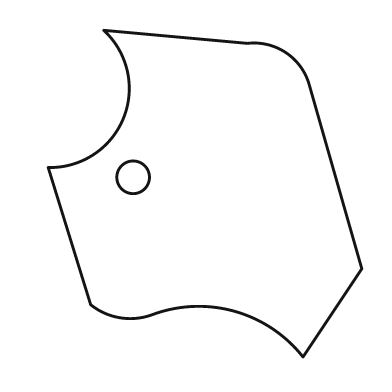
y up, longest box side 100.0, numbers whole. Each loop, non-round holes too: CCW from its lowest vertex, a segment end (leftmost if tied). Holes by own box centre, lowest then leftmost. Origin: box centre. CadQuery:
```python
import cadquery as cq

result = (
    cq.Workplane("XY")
    .moveTo(30.0, -50.0)
    .lineTo(48.0, -23.0)
    .lineTo(32.0, 33.0)
    .threePointArc((25.0, 43.0), (13.0, 46.0))
    .lineTo(-31.0, 50.0)
    .threePointArc((-25.0, 23.0), (-48.0, 8.0))
    .lineTo(-35.0, -34.0)
    .threePointArc((-26.0, -38.0), (-16.0, -37.0))
    .threePointArc((9.0, -36.0), (30.0, -50.0))
    .close()
    .moveTo(-22.0, 5.0)
    .circle(5.0)
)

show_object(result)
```